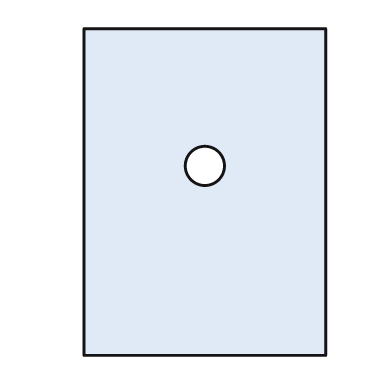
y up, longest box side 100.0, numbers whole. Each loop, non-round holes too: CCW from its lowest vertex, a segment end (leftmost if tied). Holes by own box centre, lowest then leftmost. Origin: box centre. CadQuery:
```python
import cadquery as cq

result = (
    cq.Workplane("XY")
    .moveTo(-37.0, -50.0)
    .lineTo(37.0, -50.0)
    .lineTo(37.0, 50.0)
    .lineTo(-37.0, 50.0)
    .close()
    .moveTo(0.0, 8.0)
    .circle(6.0)
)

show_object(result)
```